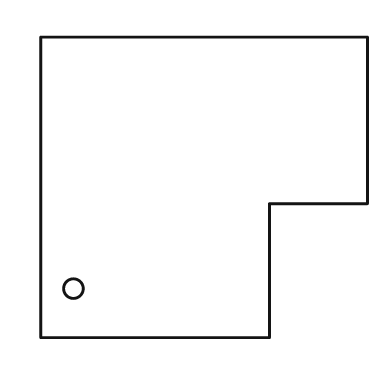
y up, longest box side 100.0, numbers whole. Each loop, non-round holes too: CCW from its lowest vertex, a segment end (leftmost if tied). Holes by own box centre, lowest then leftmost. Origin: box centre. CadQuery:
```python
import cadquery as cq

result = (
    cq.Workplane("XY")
    .moveTo(-50.0, -46.0)
    .lineTo(20.0, -46.0)
    .lineTo(20.0, -5.0)
    .lineTo(50.0, -5.0)
    .lineTo(50.0, 46.0)
    .lineTo(-50.0, 46.0)
    .close()
    .moveTo(-40.0, -31.0)
    .circle(3.0)
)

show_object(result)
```